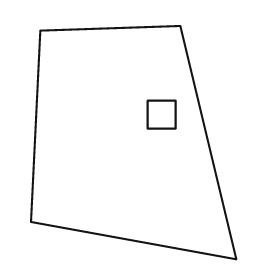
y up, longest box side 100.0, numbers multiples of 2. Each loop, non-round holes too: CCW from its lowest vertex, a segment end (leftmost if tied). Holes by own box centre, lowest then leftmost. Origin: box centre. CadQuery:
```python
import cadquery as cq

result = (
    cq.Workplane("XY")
    .moveTo(44.0, -50.0)
    .lineTo(20.0, 50.0)
    .lineTo(-40.0, 48.0)
    .lineTo(-44.0, -34.0)
    .close()
    .moveTo(6.0, 6.0)
    .lineTo(18.0, 6.0)
    .lineTo(18.0, 18.0)
    .lineTo(6.0, 18.0)
    .close()
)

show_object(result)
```